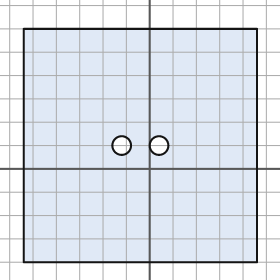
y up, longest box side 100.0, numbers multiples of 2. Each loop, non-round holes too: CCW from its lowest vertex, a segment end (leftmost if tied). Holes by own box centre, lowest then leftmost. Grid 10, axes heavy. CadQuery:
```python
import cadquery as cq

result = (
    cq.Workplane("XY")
    .moveTo(-54.0, -40.0)
    .lineTo(46.0, -40.0)
    .lineTo(46.0, 60.0)
    .lineTo(-54.0, 60.0)
    .close()
    .moveTo(-12.0, 10.0)
    .circle(4.0)
    .moveTo(4.0, 10.0)
    .circle(4.0)
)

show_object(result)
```